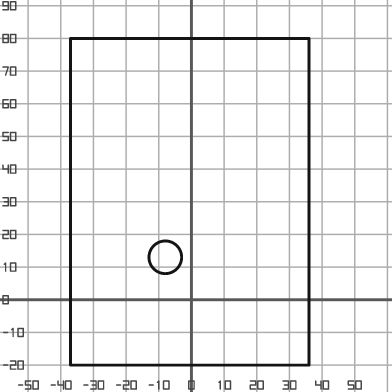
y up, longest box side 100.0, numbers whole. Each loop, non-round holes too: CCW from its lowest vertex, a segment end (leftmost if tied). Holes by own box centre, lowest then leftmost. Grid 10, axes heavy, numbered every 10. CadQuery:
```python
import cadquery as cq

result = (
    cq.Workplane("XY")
    .moveTo(-37.0, -20.0)
    .lineTo(36.0, -20.0)
    .lineTo(36.0, 80.0)
    .lineTo(-37.0, 80.0)
    .close()
    .moveTo(-8.0, 13.0)
    .circle(5.0)
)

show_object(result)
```